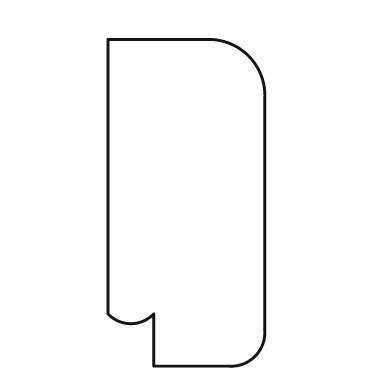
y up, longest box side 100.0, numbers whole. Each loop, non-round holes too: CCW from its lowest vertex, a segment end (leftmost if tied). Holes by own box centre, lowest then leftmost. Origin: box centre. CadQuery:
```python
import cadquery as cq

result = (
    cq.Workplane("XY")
    .moveTo(-10.0, -50.0)
    .lineTo(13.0, -50.0)
    .threePointArc((21.0, -47.0), (24.0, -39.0))
    .lineTo(24.0, 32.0)
    .threePointArc((19.0, 45.0), (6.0, 50.0))
    .lineTo(-24.0, 50.0)
    .lineTo(-24.0, -34.0)
    .threePointArc((-17.0, -37.0), (-10.0, -34.0))
    .close()
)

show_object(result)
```